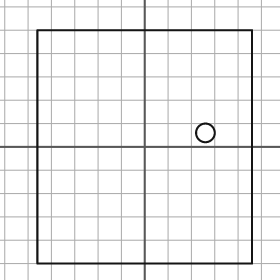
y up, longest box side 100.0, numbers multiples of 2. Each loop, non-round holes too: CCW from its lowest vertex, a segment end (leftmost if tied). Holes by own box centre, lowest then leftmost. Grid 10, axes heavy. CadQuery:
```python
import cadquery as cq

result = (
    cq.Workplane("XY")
    .moveTo(-46.0, -50.0)
    .lineTo(46.0, -50.0)
    .lineTo(46.0, 50.0)
    .lineTo(-46.0, 50.0)
    .close()
    .moveTo(26.0, 6.0)
    .circle(4.0)
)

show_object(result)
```